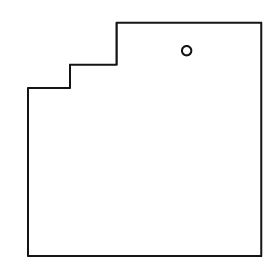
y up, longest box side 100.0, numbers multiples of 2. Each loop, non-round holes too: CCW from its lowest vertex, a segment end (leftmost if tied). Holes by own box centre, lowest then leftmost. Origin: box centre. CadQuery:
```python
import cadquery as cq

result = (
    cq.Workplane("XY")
    .moveTo(-50.0, -50.0)
    .lineTo(50.0, -50.0)
    .lineTo(50.0, 50.0)
    .lineTo(-12.0, 50.0)
    .lineTo(-12.0, 32.0)
    .lineTo(-32.0, 32.0)
    .lineTo(-32.0, 22.0)
    .lineTo(-50.0, 22.0)
    .close()
    .moveTo(18.0, 38.0)
    .circle(2.0)
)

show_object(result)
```